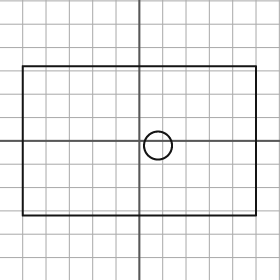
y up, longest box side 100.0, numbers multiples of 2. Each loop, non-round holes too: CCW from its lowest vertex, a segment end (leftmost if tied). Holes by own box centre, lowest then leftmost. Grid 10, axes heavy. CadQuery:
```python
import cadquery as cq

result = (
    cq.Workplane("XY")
    .moveTo(-50.0, -32.0)
    .lineTo(50.0, -32.0)
    .lineTo(50.0, 32.0)
    .lineTo(-50.0, 32.0)
    .close()
    .moveTo(8.0, -2.0)
    .circle(6.0)
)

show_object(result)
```